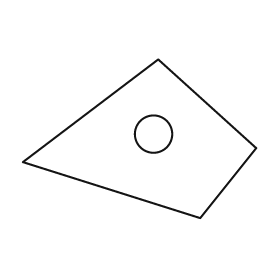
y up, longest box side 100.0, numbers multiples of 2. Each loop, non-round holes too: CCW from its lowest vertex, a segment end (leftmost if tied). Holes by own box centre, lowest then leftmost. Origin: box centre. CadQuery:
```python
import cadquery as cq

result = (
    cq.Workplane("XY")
    .moveTo(26.0, -34.0)
    .lineTo(50.0, -4.0)
    .lineTo(8.0, 34.0)
    .lineTo(-50.0, -10.0)
    .close()
    .moveTo(6.0, 2.0)
    .circle(8.0)
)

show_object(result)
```